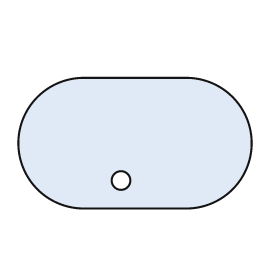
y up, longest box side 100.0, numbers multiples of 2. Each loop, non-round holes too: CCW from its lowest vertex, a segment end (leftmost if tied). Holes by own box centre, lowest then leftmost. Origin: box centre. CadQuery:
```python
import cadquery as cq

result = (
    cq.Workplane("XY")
    .moveTo(-22.0, -28.0)
    .lineTo(22.0, -28.0)
    .threePointArc((50.0, 0.0), (22.0, 28.0))
    .lineTo(-22.0, 28.0)
    .threePointArc((-50.0, 0.0), (-22.0, -28.0))
    .close()
    .moveTo(-6.0, -16.0)
    .circle(4.0)
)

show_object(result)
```